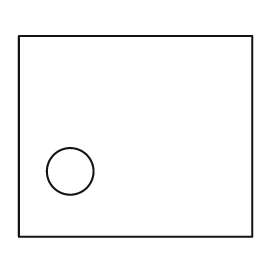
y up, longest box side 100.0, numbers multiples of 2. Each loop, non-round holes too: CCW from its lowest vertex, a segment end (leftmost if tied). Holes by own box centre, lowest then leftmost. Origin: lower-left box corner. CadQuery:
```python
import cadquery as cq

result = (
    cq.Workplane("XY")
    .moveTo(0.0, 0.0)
    .lineTo(100.0, 0.0)
    .lineTo(100.0, 86.0)
    .lineTo(0.0, 86.0)
    .close()
    .moveTo(22.0, 28.0)
    .circle(10.0)
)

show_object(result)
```